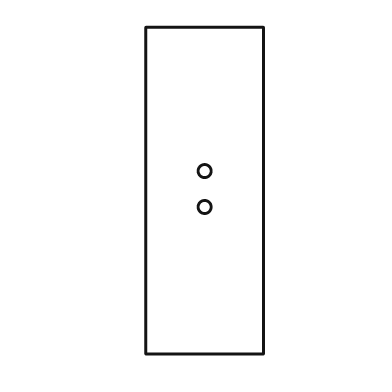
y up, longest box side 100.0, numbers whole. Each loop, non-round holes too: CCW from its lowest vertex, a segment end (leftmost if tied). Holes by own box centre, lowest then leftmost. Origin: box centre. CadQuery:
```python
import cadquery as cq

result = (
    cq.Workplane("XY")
    .moveTo(-18.0, -50.0)
    .lineTo(18.0, -50.0)
    .lineTo(18.0, 50.0)
    .lineTo(-18.0, 50.0)
    .close()
    .moveTo(0.0, -5.0)
    .circle(2.0)
    .moveTo(0.0, 6.0)
    .circle(2.0)
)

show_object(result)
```